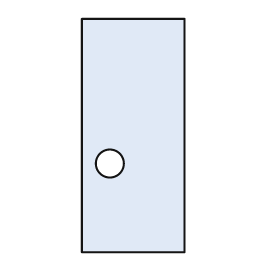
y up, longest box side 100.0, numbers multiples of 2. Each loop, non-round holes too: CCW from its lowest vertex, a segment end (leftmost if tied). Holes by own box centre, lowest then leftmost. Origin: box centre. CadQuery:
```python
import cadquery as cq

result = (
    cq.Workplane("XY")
    .moveTo(-22.0, -50.0)
    .lineTo(22.0, -50.0)
    .lineTo(22.0, 50.0)
    .lineTo(-22.0, 50.0)
    .close()
    .moveTo(-10.0, -12.0)
    .circle(6.0)
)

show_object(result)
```